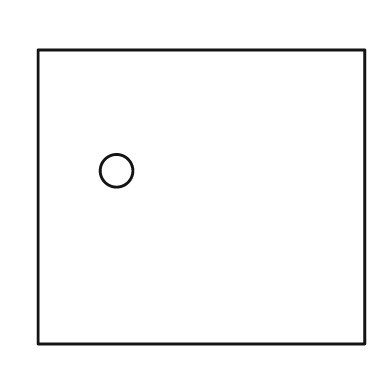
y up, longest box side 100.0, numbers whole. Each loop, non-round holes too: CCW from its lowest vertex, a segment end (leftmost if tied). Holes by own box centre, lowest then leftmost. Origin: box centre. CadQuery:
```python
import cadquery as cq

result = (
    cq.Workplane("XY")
    .moveTo(-50.0, -45.0)
    .lineTo(50.0, -45.0)
    .lineTo(50.0, 45.0)
    .lineTo(-50.0, 45.0)
    .close()
    .moveTo(-26.0, 8.0)
    .circle(5.0)
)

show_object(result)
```